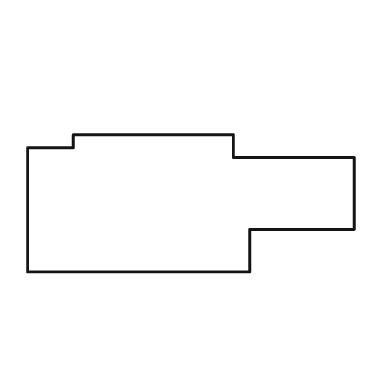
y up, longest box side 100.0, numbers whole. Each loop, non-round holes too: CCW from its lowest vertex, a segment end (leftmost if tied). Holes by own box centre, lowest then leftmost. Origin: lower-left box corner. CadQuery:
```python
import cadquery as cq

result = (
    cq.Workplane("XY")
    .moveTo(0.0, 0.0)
    .lineTo(68.0, 0.0)
    .lineTo(68.0, 13.0)
    .lineTo(100.0, 13.0)
    .lineTo(100.0, 35.0)
    .lineTo(63.0, 35.0)
    .lineTo(63.0, 42.0)
    .lineTo(14.0, 42.0)
    .lineTo(14.0, 38.0)
    .lineTo(0.0, 38.0)
    .close()
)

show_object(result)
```